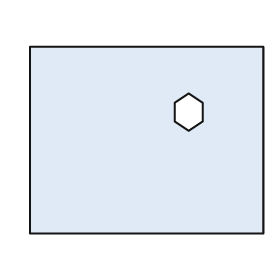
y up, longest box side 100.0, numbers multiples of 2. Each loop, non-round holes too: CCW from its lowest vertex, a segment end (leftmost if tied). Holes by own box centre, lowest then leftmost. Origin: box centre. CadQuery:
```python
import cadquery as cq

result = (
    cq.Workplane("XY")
    .moveTo(-50.0, -40.0)
    .lineTo(50.0, -40.0)
    .lineTo(50.0, 40.0)
    .lineTo(-50.0, 40.0)
    .close()
    .moveTo(18.0, 4.0)
    .lineTo(24.0, 8.0)
    .lineTo(24.0, 16.0)
    .lineTo(18.0, 20.0)
    .lineTo(12.0, 16.0)
    .lineTo(12.0, 8.0)
    .close()
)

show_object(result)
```